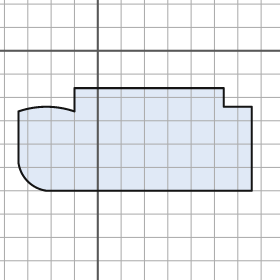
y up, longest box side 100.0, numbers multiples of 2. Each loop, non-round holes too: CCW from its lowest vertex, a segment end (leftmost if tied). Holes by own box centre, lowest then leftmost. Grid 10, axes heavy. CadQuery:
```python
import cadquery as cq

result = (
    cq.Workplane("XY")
    .moveTo(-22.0, -60.0)
    .lineTo(66.0, -60.0)
    .lineTo(66.0, -24.0)
    .lineTo(54.0, -24.0)
    .lineTo(54.0, -16.0)
    .lineTo(-10.0, -16.0)
    .lineTo(-10.0, -26.0)
    .threePointArc((-22.0, -24.0), (-34.0, -26.0))
    .lineTo(-34.0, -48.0)
    .threePointArc((-30.0, -56.0), (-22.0, -60.0))
    .close()
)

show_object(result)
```